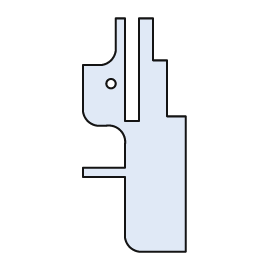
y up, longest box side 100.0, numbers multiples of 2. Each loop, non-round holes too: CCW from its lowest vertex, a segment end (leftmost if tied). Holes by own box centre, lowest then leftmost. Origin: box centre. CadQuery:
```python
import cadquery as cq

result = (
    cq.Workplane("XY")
    .moveTo(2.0, -50.0)
    .lineTo(22.0, -50.0)
    .lineTo(22.0, 8.0)
    .lineTo(14.0, 8.0)
    .lineTo(14.0, 32.0)
    .lineTo(8.0, 32.0)
    .lineTo(8.0, 50.0)
    .lineTo(2.0, 50.0)
    .lineTo(2.0, 6.0)
    .lineTo(-4.0, 6.0)
    .lineTo(-4.0, 50.0)
    .lineTo(-8.0, 50.0)
    .lineTo(-8.0, 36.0)
    .threePointArc((-10.0, 32.0), (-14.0, 30.0))
    .lineTo(-22.0, 30.0)
    .lineTo(-22.0, 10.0)
    .threePointArc((-20.0, 6.0), (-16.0, 4.0))
    .lineTo(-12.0, 4.0)
    .threePointArc((-6.0, 2.0), (-4.0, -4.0))
    .lineTo(-4.0, -14.0)
    .lineTo(-22.0, -14.0)
    .lineTo(-22.0, -18.0)
    .lineTo(-4.0, -18.0)
    .lineTo(-4.0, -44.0)
    .threePointArc((-2.0, -48.0), (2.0, -50.0))
    .close()
    .moveTo(-10.0, 22.0)
    .circle(2.0)
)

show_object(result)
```